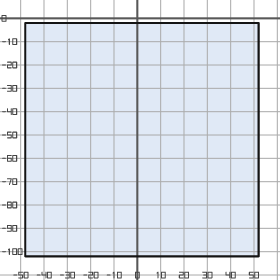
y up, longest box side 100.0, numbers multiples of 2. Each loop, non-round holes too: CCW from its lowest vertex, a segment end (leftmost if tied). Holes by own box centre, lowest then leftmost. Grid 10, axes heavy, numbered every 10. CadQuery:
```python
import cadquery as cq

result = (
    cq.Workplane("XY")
    .moveTo(-48.0, -102.0)
    .lineTo(52.0, -102.0)
    .lineTo(52.0, -2.0)
    .lineTo(-48.0, -2.0)
    .close()
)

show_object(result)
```